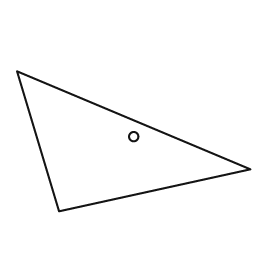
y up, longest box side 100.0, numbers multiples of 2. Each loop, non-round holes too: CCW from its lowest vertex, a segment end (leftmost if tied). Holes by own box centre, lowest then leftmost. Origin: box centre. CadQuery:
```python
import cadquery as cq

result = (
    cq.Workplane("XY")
    .moveTo(-32.0, -30.0)
    .lineTo(50.0, -12.0)
    .lineTo(-50.0, 30.0)
    .close()
    .moveTo(0.0, 2.0)
    .circle(2.0)
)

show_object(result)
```